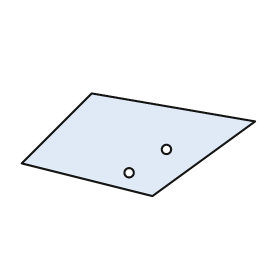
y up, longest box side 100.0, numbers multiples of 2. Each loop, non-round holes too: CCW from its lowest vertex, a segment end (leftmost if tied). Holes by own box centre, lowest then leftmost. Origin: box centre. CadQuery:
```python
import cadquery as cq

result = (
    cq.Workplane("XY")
    .moveTo(6.0, -22.0)
    .lineTo(50.0, 10.0)
    .lineTo(-20.0, 22.0)
    .lineTo(-50.0, -8.0)
    .close()
    .moveTo(-4.0, -12.0)
    .circle(2.0)
    .moveTo(12.0, -2.0)
    .circle(2.0)
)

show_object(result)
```